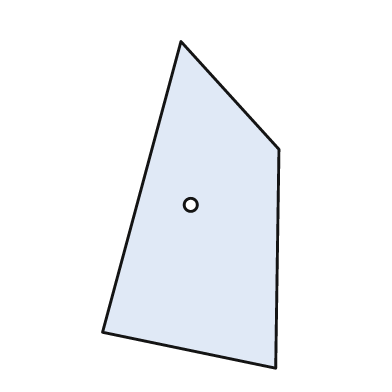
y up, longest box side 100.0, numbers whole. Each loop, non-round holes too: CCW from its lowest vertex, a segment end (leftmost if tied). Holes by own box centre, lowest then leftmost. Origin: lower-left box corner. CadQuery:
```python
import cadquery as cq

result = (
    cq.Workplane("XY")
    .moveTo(53.0, 0.0)
    .lineTo(54.0, 67.0)
    .lineTo(24.0, 100.0)
    .lineTo(0.0, 11.0)
    .close()
    .moveTo(27.0, 50.0)
    .circle(2.0)
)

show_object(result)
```